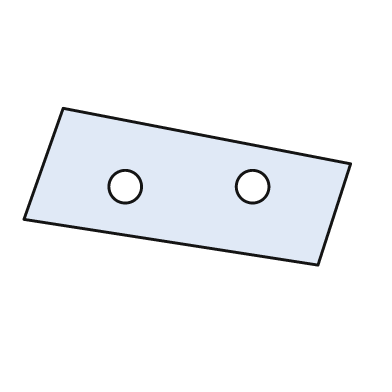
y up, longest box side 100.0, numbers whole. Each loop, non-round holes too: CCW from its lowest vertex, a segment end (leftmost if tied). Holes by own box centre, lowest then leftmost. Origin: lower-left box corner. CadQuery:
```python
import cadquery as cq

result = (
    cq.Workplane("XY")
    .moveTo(90.0, 0.0)
    .lineTo(100.0, 31.0)
    .lineTo(12.0, 48.0)
    .lineTo(0.0, 14.0)
    .close()
    .moveTo(31.0, 24.0)
    .circle(5.0)
    .moveTo(70.0, 24.0)
    .circle(5.0)
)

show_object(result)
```